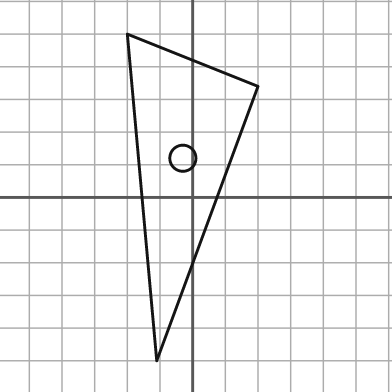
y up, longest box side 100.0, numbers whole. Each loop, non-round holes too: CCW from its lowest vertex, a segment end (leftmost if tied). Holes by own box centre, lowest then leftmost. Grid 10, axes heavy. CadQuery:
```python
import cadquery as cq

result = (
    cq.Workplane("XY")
    .moveTo(-11.0, -50.0)
    .lineTo(20.0, 34.0)
    .lineTo(-20.0, 50.0)
    .close()
    .moveTo(-3.0, 12.0)
    .circle(4.0)
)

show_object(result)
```